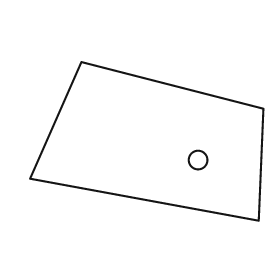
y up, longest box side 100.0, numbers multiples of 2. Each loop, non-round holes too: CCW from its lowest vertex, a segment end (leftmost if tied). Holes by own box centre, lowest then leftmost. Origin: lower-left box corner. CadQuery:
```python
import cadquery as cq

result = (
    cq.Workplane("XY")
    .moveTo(98.0, 0.0)
    .lineTo(100.0, 48.0)
    .lineTo(22.0, 68.0)
    .lineTo(0.0, 18.0)
    .close()
    .moveTo(72.0, 26.0)
    .circle(4.0)
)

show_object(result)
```